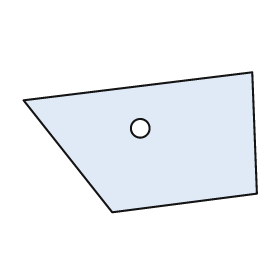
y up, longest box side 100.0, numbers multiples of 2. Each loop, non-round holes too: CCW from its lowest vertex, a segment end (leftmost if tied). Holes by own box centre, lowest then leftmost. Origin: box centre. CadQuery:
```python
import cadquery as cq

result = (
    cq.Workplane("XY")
    .moveTo(-12.0, -30.0)
    .lineTo(50.0, -22.0)
    .lineTo(48.0, 30.0)
    .lineTo(-50.0, 18.0)
    .close()
    .moveTo(0.0, 6.0)
    .circle(4.0)
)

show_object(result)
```